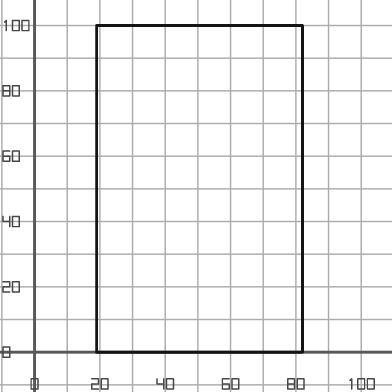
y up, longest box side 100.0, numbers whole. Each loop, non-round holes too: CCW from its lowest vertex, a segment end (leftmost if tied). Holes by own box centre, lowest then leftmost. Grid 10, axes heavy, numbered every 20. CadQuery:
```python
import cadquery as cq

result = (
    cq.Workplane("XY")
    .moveTo(19.0, 0.0)
    .lineTo(82.0, 0.0)
    .lineTo(82.0, 100.0)
    .lineTo(19.0, 100.0)
    .close()
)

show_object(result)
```